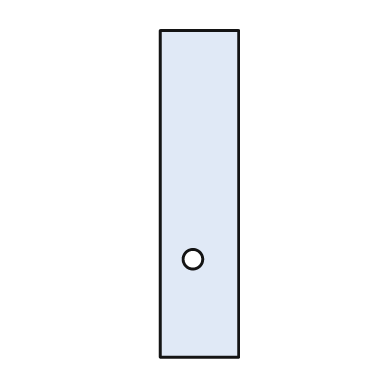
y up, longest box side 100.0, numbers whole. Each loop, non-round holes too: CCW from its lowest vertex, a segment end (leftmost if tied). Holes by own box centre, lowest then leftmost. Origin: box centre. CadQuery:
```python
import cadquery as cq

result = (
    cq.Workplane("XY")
    .moveTo(-12.0, -50.0)
    .lineTo(12.0, -50.0)
    .lineTo(12.0, 50.0)
    .lineTo(-12.0, 50.0)
    .close()
    .moveTo(-2.0, -20.0)
    .circle(3.0)
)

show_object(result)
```